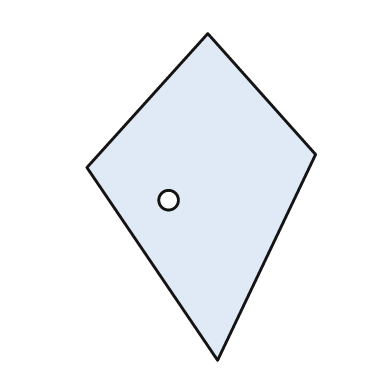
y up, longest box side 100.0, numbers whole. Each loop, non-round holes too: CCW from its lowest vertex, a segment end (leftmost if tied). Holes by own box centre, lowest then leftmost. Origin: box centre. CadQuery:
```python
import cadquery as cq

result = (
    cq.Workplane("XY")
    .moveTo(5.0, -50.0)
    .lineTo(35.0, 13.0)
    .lineTo(2.0, 50.0)
    .lineTo(-35.0, 9.0)
    .close()
    .moveTo(-10.0, -1.0)
    .circle(3.0)
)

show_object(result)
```